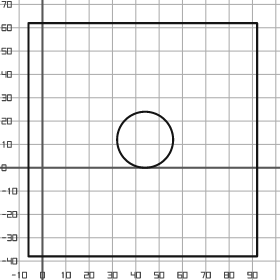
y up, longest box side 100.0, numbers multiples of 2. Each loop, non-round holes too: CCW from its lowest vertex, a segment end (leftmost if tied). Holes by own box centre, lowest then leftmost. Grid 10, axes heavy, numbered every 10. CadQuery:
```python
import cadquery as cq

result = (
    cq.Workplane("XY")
    .moveTo(-6.0, -38.0)
    .lineTo(92.0, -38.0)
    .lineTo(92.0, 62.0)
    .lineTo(-6.0, 62.0)
    .close()
    .moveTo(44.0, 12.0)
    .circle(12.0)
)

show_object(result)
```